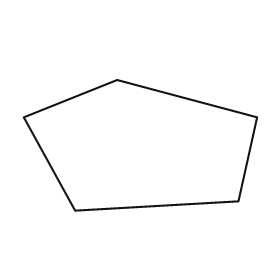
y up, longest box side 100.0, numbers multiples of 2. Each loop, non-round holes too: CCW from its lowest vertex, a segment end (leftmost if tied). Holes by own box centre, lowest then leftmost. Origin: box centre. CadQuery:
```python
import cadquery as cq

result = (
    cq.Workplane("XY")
    .moveTo(-28.0, -28.0)
    .lineTo(42.0, -24.0)
    .lineTo(50.0, 12.0)
    .lineTo(-10.0, 28.0)
    .lineTo(-50.0, 12.0)
    .close()
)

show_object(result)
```